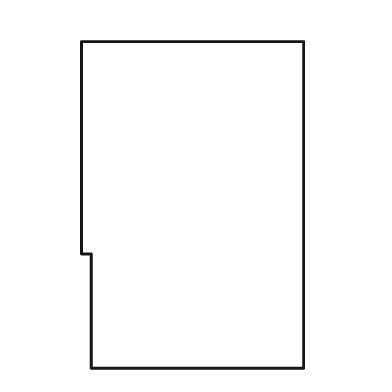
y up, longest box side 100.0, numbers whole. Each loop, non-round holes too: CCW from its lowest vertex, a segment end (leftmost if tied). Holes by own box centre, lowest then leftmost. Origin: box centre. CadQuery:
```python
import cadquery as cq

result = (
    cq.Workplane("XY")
    .moveTo(-31.0, -50.0)
    .lineTo(34.0, -50.0)
    .lineTo(34.0, 50.0)
    .lineTo(-34.0, 50.0)
    .lineTo(-34.0, -15.0)
    .lineTo(-31.0, -15.0)
    .close()
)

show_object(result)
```